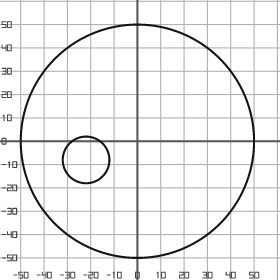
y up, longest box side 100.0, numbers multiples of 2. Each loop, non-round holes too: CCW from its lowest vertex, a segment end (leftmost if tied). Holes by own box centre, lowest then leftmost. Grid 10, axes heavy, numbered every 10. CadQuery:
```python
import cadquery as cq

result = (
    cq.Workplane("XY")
    .moveTo(0.0, 0.0)
    .circle(50.0)
    .moveTo(-22.0, -8.0)
    .circle(10.0)
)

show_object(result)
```